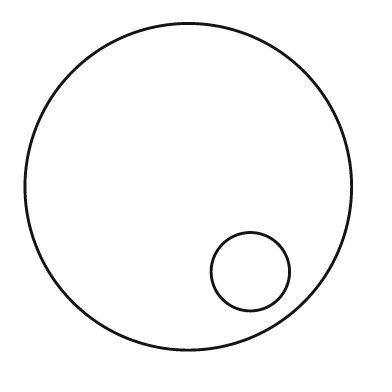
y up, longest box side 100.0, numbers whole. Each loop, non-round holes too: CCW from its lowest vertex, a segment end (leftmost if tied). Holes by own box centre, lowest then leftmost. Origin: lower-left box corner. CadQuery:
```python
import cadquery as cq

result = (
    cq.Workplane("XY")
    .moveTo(50.0, 50.0)
    .circle(50.0)
    .moveTo(69.0, 24.0)
    .circle(12.0)
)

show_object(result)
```